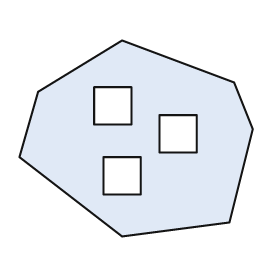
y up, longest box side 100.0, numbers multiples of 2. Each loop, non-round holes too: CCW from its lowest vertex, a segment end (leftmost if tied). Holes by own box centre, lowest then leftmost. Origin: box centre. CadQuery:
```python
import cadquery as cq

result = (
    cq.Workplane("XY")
    .moveTo(-6.0, -42.0)
    .lineTo(40.0, -36.0)
    .lineTo(50.0, 4.0)
    .lineTo(42.0, 24.0)
    .lineTo(-6.0, 42.0)
    .lineTo(-42.0, 20.0)
    .lineTo(-50.0, -8.0)
    .close()
    .moveTo(-14.0, -24.0)
    .lineTo(2.0, -24.0)
    .lineTo(2.0, -8.0)
    .lineTo(-14.0, -8.0)
    .close()
    .moveTo(10.0, -6.0)
    .lineTo(26.0, -6.0)
    .lineTo(26.0, 10.0)
    .lineTo(10.0, 10.0)
    .close()
    .moveTo(-18.0, 6.0)
    .lineTo(-2.0, 6.0)
    .lineTo(-2.0, 22.0)
    .lineTo(-18.0, 22.0)
    .close()
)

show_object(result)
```